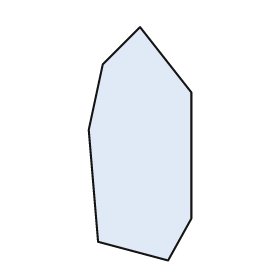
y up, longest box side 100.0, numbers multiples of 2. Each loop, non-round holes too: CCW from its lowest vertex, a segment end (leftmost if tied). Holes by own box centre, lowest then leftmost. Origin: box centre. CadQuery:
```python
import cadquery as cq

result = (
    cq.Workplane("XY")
    .moveTo(12.0, -50.0)
    .lineTo(22.0, -32.0)
    .lineTo(22.0, 22.0)
    .lineTo(0.0, 50.0)
    .lineTo(-16.0, 34.0)
    .lineTo(-22.0, 6.0)
    .lineTo(-18.0, -42.0)
    .close()
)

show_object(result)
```